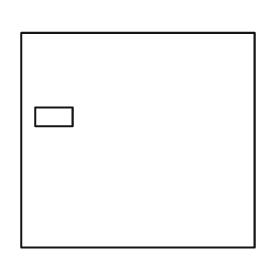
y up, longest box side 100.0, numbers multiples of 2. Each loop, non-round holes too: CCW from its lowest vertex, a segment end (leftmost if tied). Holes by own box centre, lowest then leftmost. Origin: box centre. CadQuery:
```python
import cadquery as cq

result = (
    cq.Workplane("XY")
    .moveTo(-50.0, -46.0)
    .lineTo(50.0, -46.0)
    .lineTo(50.0, 46.0)
    .lineTo(-50.0, 46.0)
    .close()
    .moveTo(-44.0, 6.0)
    .lineTo(-28.0, 6.0)
    .lineTo(-28.0, 14.0)
    .lineTo(-44.0, 14.0)
    .close()
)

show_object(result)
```